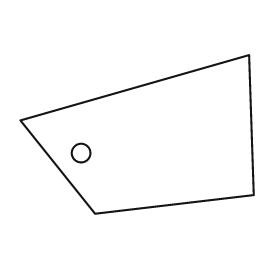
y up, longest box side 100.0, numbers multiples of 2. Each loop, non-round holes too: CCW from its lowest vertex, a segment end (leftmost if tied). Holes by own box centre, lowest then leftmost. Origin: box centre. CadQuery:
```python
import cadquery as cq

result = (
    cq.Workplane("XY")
    .moveTo(-18.0, -34.0)
    .lineTo(50.0, -26.0)
    .lineTo(48.0, 34.0)
    .lineTo(-50.0, 6.0)
    .close()
    .moveTo(-24.0, -8.0)
    .circle(4.0)
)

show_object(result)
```